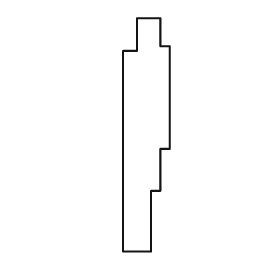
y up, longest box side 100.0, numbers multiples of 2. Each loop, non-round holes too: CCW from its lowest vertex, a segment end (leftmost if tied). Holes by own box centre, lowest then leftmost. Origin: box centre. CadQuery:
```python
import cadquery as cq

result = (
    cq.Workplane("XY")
    .moveTo(-10.0, -50.0)
    .lineTo(2.0, -50.0)
    .lineTo(2.0, -24.0)
    .lineTo(6.0, -24.0)
    .lineTo(6.0, -6.0)
    .lineTo(10.0, -6.0)
    .lineTo(10.0, 38.0)
    .lineTo(6.0, 38.0)
    .lineTo(6.0, 50.0)
    .lineTo(-4.0, 50.0)
    .lineTo(-4.0, 36.0)
    .lineTo(-10.0, 36.0)
    .close()
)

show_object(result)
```